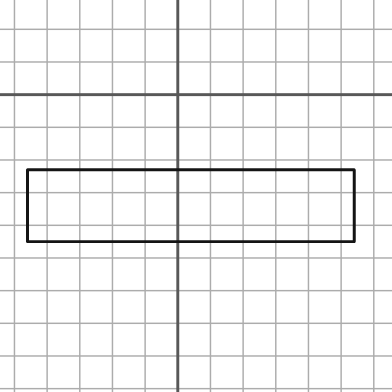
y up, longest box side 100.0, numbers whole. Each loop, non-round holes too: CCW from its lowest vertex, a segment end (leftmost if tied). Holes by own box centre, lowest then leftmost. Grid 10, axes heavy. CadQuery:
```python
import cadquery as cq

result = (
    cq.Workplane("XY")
    .moveTo(-46.0, -45.0)
    .lineTo(54.0, -45.0)
    .lineTo(54.0, -23.0)
    .lineTo(-46.0, -23.0)
    .close()
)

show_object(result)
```